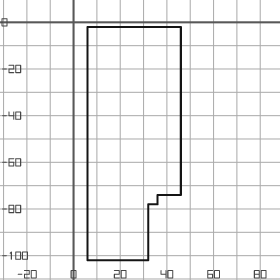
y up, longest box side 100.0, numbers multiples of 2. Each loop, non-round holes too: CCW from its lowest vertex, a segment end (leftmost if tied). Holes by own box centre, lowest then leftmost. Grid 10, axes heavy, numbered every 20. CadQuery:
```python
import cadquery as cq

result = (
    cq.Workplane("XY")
    .moveTo(6.0, -102.0)
    .lineTo(32.0, -102.0)
    .lineTo(32.0, -78.0)
    .lineTo(36.0, -78.0)
    .lineTo(36.0, -74.0)
    .lineTo(46.0, -74.0)
    .lineTo(46.0, -2.0)
    .lineTo(6.0, -2.0)
    .close()
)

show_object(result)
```